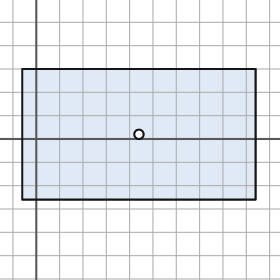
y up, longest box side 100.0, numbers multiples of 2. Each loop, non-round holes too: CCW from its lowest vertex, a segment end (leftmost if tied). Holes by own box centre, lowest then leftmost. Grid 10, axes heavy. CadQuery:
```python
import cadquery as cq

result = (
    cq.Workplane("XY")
    .moveTo(-6.0, -26.0)
    .lineTo(94.0, -26.0)
    .lineTo(94.0, 30.0)
    .lineTo(-6.0, 30.0)
    .close()
    .moveTo(44.0, 2.0)
    .circle(2.0)
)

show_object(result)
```